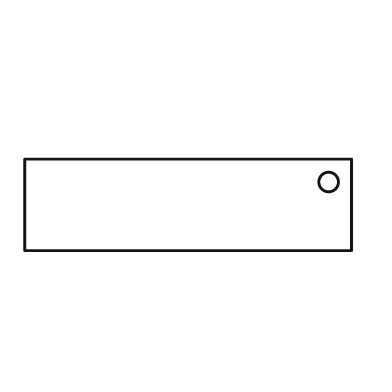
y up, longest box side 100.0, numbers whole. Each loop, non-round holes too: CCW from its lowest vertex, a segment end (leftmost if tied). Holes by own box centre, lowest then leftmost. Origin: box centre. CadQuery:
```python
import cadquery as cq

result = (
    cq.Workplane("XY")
    .moveTo(-50.0, -14.0)
    .lineTo(50.0, -14.0)
    .lineTo(50.0, 14.0)
    .lineTo(-50.0, 14.0)
    .close()
    .moveTo(43.0, 7.0)
    .circle(3.0)
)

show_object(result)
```